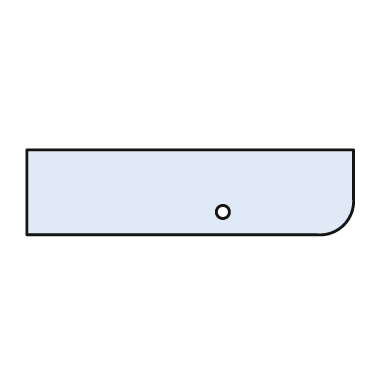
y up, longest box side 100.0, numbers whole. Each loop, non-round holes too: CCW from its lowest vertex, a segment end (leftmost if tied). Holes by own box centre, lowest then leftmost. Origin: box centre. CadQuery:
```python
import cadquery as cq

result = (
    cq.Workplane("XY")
    .moveTo(-50.0, -13.0)
    .lineTo(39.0, -13.0)
    .threePointArc((47.0, -10.0), (50.0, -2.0))
    .lineTo(50.0, 13.0)
    .lineTo(-50.0, 13.0)
    .close()
    .moveTo(10.0, -6.0)
    .circle(2.0)
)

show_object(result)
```